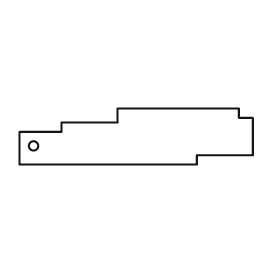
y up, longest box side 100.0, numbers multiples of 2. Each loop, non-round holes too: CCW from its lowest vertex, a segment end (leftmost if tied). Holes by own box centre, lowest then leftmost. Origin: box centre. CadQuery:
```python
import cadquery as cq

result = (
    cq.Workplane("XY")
    .moveTo(-50.0, -12.0)
    .lineTo(26.0, -12.0)
    .lineTo(26.0, -8.0)
    .lineTo(50.0, -8.0)
    .lineTo(50.0, 8.0)
    .lineTo(44.0, 8.0)
    .lineTo(44.0, 12.0)
    .lineTo(-8.0, 12.0)
    .lineTo(-8.0, 6.0)
    .lineTo(-32.0, 6.0)
    .lineTo(-32.0, 2.0)
    .lineTo(-50.0, 2.0)
    .close()
    .moveTo(-44.0, -4.0)
    .circle(2.0)
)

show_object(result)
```